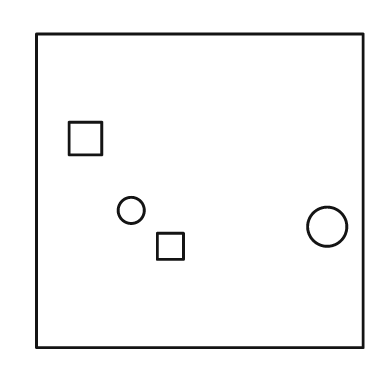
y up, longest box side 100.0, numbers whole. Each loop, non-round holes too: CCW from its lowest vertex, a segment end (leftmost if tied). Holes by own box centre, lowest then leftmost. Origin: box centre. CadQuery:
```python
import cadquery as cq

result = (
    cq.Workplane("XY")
    .moveTo(-50.0, -48.0)
    .lineTo(50.0, -48.0)
    .lineTo(50.0, 48.0)
    .lineTo(-50.0, 48.0)
    .close()
    .moveTo(-13.0, -21.0)
    .lineTo(-5.0, -21.0)
    .lineTo(-5.0, -13.0)
    .lineTo(-13.0, -13.0)
    .close()
    .moveTo(39.0, -11.0)
    .circle(6.0)
    .moveTo(-21.0, -6.0)
    .circle(4.0)
    .moveTo(-40.0, 11.0)
    .lineTo(-30.0, 11.0)
    .lineTo(-30.0, 21.0)
    .lineTo(-40.0, 21.0)
    .close()
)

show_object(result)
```